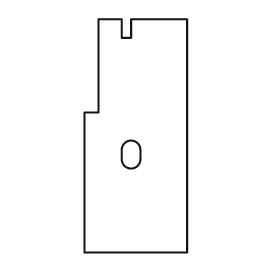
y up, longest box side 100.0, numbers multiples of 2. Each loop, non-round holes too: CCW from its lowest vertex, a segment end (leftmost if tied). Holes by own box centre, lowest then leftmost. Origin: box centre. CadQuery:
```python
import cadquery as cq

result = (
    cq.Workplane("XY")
    .moveTo(-22.0, -50.0)
    .lineTo(22.0, -50.0)
    .lineTo(22.0, 50.0)
    .lineTo(-2.0, 50.0)
    .lineTo(-2.0, 42.0)
    .lineTo(-6.0, 42.0)
    .lineTo(-6.0, 50.0)
    .lineTo(-16.0, 50.0)
    .lineTo(-16.0, 10.0)
    .lineTo(-22.0, 10.0)
    .close()
    .moveTo(-6.0, -10.0)
    .threePointArc((-2.0, -14.0), (2.0, -10.0))
    .lineTo(2.0, -6.0)
    .threePointArc((-2.0, -2.0), (-6.0, -6.0))
    .close()
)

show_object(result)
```